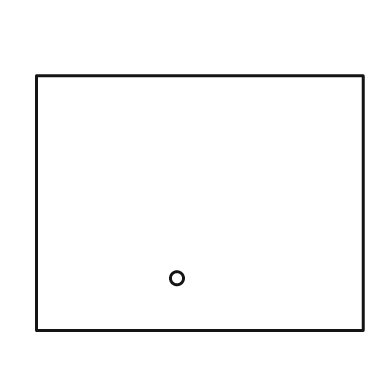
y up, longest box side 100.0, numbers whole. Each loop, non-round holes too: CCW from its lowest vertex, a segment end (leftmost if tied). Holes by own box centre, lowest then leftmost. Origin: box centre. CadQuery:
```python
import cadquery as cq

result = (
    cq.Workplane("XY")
    .moveTo(-50.0, -39.0)
    .lineTo(50.0, -39.0)
    .lineTo(50.0, 39.0)
    .lineTo(-50.0, 39.0)
    .close()
    .moveTo(-7.0, -23.0)
    .circle(2.0)
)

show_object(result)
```